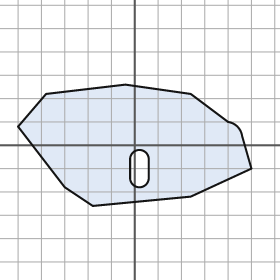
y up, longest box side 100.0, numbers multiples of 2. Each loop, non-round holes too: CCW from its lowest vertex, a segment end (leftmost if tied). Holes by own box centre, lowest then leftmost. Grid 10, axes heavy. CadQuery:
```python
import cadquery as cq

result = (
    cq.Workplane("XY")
    .moveTo(-18.0, -26.0)
    .lineTo(24.0, -22.0)
    .lineTo(50.0, -10.0)
    .lineTo(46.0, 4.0)
    .threePointArc((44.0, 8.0), (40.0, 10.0))
    .lineTo(24.0, 22.0)
    .lineTo(-4.0, 26.0)
    .lineTo(-38.0, 22.0)
    .lineTo(-50.0, 8.0)
    .lineTo(-30.0, -18.0)
    .close()
    .moveTo(-2.0, -14.0)
    .threePointArc((2.0, -18.0), (6.0, -14.0))
    .lineTo(6.0, -6.0)
    .threePointArc((2.0, -2.0), (-2.0, -6.0))
    .close()
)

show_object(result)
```